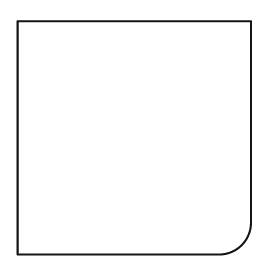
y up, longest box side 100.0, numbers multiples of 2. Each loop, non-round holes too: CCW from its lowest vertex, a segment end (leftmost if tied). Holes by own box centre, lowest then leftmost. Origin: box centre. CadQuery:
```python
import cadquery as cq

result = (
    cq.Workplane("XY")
    .moveTo(-50.0, -50.0)
    .lineTo(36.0, -50.0)
    .threePointArc((46.0, -46.0), (50.0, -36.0))
    .lineTo(50.0, 50.0)
    .lineTo(-50.0, 50.0)
    .close()
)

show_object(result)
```